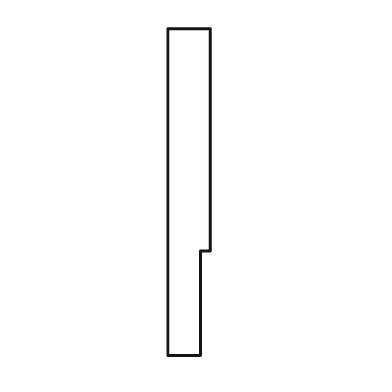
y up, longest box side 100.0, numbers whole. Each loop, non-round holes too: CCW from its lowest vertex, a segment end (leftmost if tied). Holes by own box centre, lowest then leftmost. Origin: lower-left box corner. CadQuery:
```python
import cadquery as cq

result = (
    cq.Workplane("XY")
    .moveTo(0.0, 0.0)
    .lineTo(10.0, 0.0)
    .lineTo(10.0, 32.0)
    .lineTo(13.0, 32.0)
    .lineTo(13.0, 100.0)
    .lineTo(0.0, 100.0)
    .close()
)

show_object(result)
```